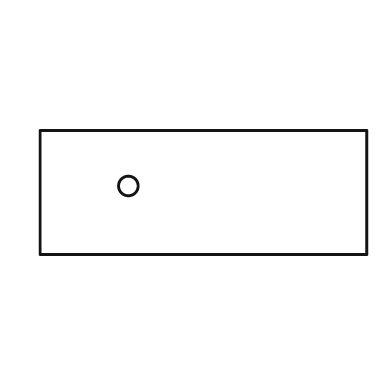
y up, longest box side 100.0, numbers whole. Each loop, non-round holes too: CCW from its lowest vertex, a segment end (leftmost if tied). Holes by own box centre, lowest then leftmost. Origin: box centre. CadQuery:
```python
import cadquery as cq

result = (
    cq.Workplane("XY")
    .moveTo(-50.0, -19.0)
    .lineTo(50.0, -19.0)
    .lineTo(50.0, 19.0)
    .lineTo(-50.0, 19.0)
    .close()
    .moveTo(-23.0, 2.0)
    .circle(3.0)
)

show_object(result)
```